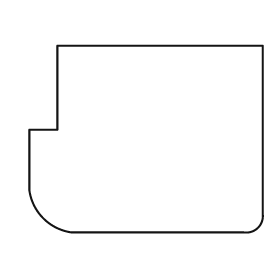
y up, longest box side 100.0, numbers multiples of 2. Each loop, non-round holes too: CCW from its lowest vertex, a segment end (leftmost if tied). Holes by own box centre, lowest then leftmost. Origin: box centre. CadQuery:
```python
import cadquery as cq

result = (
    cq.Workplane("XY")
    .moveTo(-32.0, -40.0)
    .lineTo(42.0, -40.0)
    .threePointArc((48.0, -38.0), (50.0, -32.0))
    .lineTo(50.0, 40.0)
    .lineTo(-38.0, 40.0)
    .lineTo(-38.0, 4.0)
    .lineTo(-50.0, 4.0)
    .lineTo(-50.0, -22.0)
    .threePointArc((-44.0, -34.0), (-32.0, -40.0))
    .close()
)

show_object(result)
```